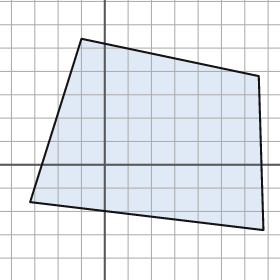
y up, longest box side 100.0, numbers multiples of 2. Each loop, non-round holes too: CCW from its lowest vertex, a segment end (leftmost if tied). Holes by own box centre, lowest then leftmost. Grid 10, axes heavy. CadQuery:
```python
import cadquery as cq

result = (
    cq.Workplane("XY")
    .moveTo(68.0, -28.0)
    .lineTo(66.0, 38.0)
    .lineTo(-10.0, 54.0)
    .lineTo(-32.0, -16.0)
    .close()
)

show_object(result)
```